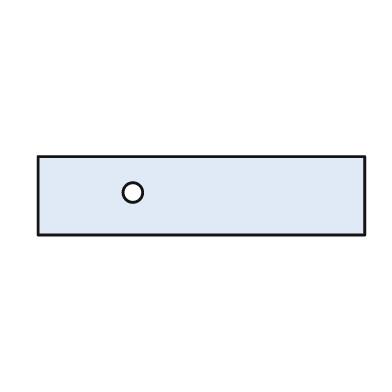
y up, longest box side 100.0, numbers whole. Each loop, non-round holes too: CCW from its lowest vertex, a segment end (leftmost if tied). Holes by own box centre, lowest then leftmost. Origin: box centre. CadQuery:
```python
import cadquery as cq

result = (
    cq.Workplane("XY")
    .moveTo(-50.0, -12.0)
    .lineTo(50.0, -12.0)
    .lineTo(50.0, 12.0)
    .lineTo(-50.0, 12.0)
    .close()
    .moveTo(-21.0, 1.0)
    .circle(3.0)
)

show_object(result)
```